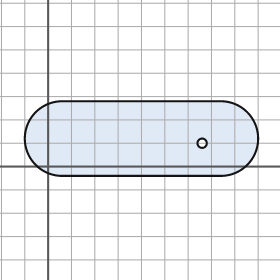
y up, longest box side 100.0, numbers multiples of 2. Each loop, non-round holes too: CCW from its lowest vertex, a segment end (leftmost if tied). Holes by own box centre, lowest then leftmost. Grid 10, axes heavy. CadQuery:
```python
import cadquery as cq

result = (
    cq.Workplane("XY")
    .moveTo(6.0, -4.0)
    .lineTo(74.0, -4.0)
    .threePointArc((90.0, 12.0), (74.0, 28.0))
    .lineTo(6.0, 28.0)
    .threePointArc((-10.0, 12.0), (6.0, -4.0))
    .close()
    .moveTo(66.0, 10.0)
    .circle(2.0)
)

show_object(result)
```